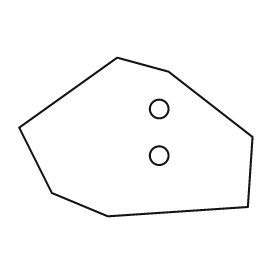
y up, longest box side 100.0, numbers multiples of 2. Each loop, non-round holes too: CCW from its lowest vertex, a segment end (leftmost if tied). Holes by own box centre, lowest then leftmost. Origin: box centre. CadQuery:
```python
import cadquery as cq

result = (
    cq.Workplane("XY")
    .moveTo(-12.0, -34.0)
    .lineTo(48.0, -30.0)
    .lineTo(50.0, 0.0)
    .lineTo(14.0, 28.0)
    .lineTo(-8.0, 34.0)
    .lineTo(-50.0, 4.0)
    .lineTo(-36.0, -24.0)
    .close()
    .moveTo(10.0, -8.0)
    .circle(4.0)
    .moveTo(10.0, 12.0)
    .circle(4.0)
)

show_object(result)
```